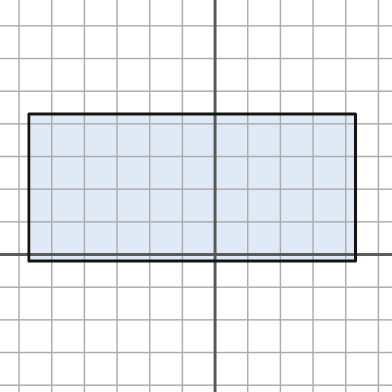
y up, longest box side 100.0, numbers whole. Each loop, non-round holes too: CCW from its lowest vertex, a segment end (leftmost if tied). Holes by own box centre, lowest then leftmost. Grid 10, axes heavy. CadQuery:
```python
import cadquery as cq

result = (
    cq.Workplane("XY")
    .moveTo(-57.0, -2.0)
    .lineTo(43.0, -2.0)
    .lineTo(43.0, 43.0)
    .lineTo(-57.0, 43.0)
    .close()
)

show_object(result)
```